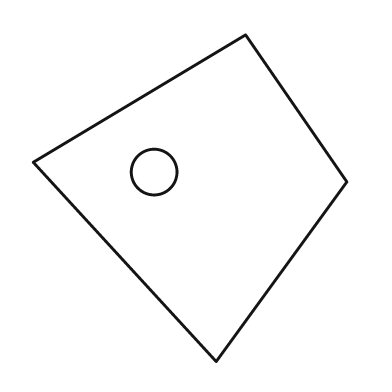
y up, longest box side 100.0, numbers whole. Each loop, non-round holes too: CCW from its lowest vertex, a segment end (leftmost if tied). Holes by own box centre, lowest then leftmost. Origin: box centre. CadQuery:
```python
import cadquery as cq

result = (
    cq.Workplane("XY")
    .moveTo(8.0, -50.0)
    .lineTo(48.0, 5.0)
    .lineTo(17.0, 50.0)
    .lineTo(-48.0, 11.0)
    .close()
    .moveTo(-11.0, 8.0)
    .circle(7.0)
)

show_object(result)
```